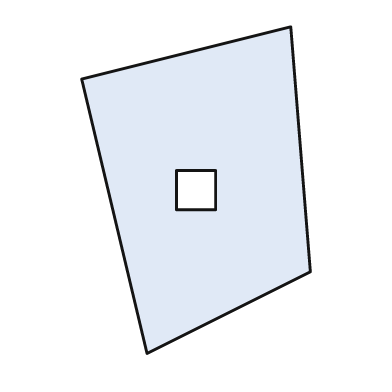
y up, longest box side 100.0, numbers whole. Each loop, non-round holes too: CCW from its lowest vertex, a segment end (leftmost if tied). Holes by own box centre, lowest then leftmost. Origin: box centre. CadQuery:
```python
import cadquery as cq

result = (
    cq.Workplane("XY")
    .moveTo(-15.0, -50.0)
    .lineTo(35.0, -25.0)
    .lineTo(29.0, 50.0)
    .lineTo(-35.0, 34.0)
    .close()
    .moveTo(-6.0, -6.0)
    .lineTo(6.0, -6.0)
    .lineTo(6.0, 6.0)
    .lineTo(-6.0, 6.0)
    .close()
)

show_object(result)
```